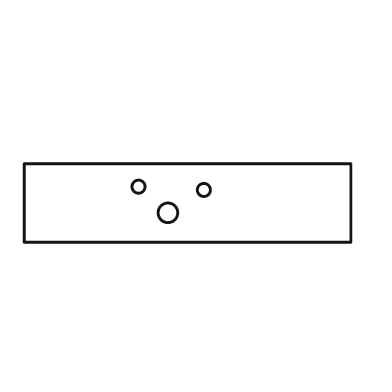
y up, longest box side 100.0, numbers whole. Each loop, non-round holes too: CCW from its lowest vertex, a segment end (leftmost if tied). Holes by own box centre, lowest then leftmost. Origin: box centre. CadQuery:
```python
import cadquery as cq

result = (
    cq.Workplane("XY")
    .moveTo(-50.0, -12.0)
    .lineTo(50.0, -12.0)
    .lineTo(50.0, 12.0)
    .lineTo(-50.0, 12.0)
    .close()
    .moveTo(-6.0, -3.0)
    .circle(3.0)
    .moveTo(5.0, 4.0)
    .circle(2.0)
    .moveTo(-15.0, 5.0)
    .circle(2.0)
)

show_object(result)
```